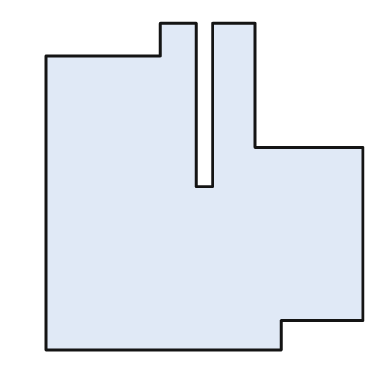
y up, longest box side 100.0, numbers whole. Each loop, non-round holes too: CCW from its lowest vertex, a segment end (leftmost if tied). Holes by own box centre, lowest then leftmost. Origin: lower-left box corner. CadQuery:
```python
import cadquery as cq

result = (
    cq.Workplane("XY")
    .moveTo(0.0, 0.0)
    .lineTo(72.0, 0.0)
    .lineTo(72.0, 9.0)
    .lineTo(97.0, 9.0)
    .lineTo(97.0, 62.0)
    .lineTo(64.0, 62.0)
    .lineTo(64.0, 100.0)
    .lineTo(51.0, 100.0)
    .lineTo(51.0, 50.0)
    .lineTo(46.0, 50.0)
    .lineTo(46.0, 100.0)
    .lineTo(35.0, 100.0)
    .lineTo(35.0, 90.0)
    .lineTo(0.0, 90.0)
    .close()
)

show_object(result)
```